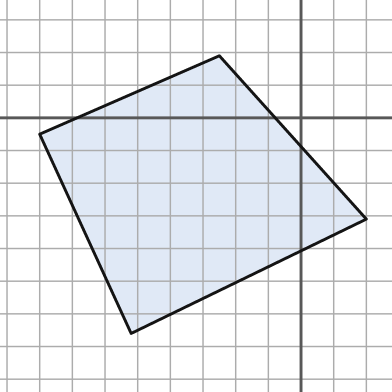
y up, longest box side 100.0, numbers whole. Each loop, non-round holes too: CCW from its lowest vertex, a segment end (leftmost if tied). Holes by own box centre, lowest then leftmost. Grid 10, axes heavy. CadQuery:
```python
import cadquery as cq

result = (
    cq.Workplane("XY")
    .moveTo(-52.0, -66.0)
    .lineTo(20.0, -31.0)
    .lineTo(-25.0, 19.0)
    .lineTo(-80.0, -5.0)
    .close()
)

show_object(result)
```